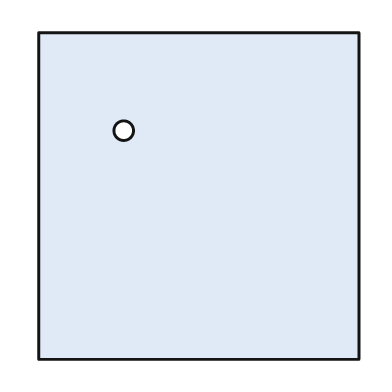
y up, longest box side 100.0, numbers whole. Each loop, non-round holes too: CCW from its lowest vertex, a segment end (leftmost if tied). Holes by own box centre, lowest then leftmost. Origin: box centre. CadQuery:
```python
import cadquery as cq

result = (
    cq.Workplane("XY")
    .moveTo(-49.0, -50.0)
    .lineTo(49.0, -50.0)
    .lineTo(49.0, 50.0)
    .lineTo(-49.0, 50.0)
    .close()
    .moveTo(-23.0, 20.0)
    .circle(3.0)
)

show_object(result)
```